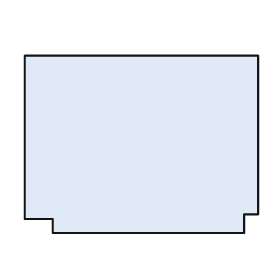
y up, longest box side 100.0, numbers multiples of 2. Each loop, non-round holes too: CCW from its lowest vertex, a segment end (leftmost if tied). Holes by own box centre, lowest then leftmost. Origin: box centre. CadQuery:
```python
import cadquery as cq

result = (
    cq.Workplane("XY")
    .moveTo(-38.0, -38.0)
    .lineTo(44.0, -38.0)
    .lineTo(44.0, -30.0)
    .lineTo(50.0, -30.0)
    .lineTo(50.0, 38.0)
    .lineTo(-50.0, 38.0)
    .lineTo(-50.0, -32.0)
    .lineTo(-38.0, -32.0)
    .close()
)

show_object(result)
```